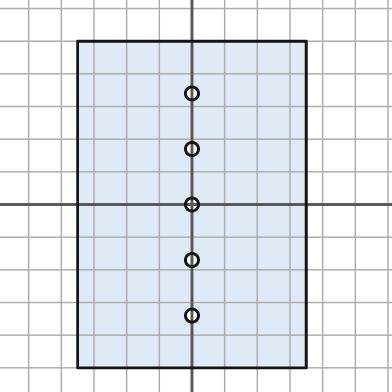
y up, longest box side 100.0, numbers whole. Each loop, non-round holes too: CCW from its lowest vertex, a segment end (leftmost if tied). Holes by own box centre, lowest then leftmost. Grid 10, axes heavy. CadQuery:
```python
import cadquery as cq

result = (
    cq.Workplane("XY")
    .moveTo(-35.0, -50.0)
    .lineTo(35.0, -50.0)
    .lineTo(35.0, 50.0)
    .lineTo(-35.0, 50.0)
    .close()
    .moveTo(0.0, -34.0)
    .circle(2.0)
    .moveTo(0.0, -17.0)
    .circle(2.0)
    .moveTo(0.0, 0.0)
    .circle(2.0)
    .moveTo(0.0, 17.0)
    .circle(2.0)
    .moveTo(0.0, 34.0)
    .circle(2.0)
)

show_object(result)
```